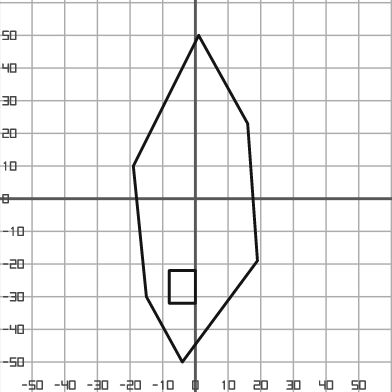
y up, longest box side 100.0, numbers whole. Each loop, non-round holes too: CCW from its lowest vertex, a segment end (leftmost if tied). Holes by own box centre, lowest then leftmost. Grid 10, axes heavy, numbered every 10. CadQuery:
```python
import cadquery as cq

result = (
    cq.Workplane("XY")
    .moveTo(-4.0, -50.0)
    .lineTo(19.0, -19.0)
    .lineTo(16.0, 23.0)
    .lineTo(1.0, 50.0)
    .lineTo(-19.0, 10.0)
    .lineTo(-15.0, -30.0)
    .close()
    .moveTo(-8.0, -32.0)
    .lineTo(0.0, -32.0)
    .lineTo(0.0, -22.0)
    .lineTo(-8.0, -22.0)
    .close()
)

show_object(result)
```